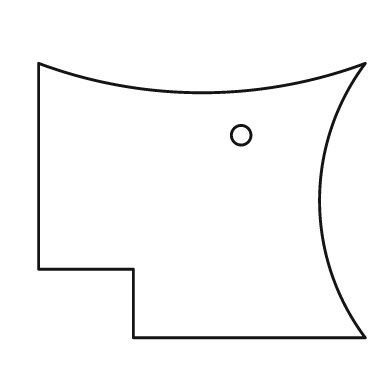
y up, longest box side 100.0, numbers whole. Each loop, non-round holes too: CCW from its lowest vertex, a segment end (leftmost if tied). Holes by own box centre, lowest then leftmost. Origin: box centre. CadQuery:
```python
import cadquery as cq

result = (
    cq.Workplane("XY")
    .moveTo(-21.0, -42.0)
    .lineTo(50.0, -42.0)
    .threePointArc((36.0, 0.0), (50.0, 42.0))
    .threePointArc((0.0, 33.0), (-50.0, 42.0))
    .lineTo(-50.0, -21.0)
    .lineTo(-21.0, -21.0)
    .close()
    .moveTo(12.0, 20.0)
    .circle(3.0)
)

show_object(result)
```